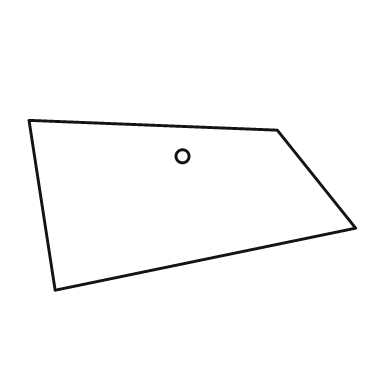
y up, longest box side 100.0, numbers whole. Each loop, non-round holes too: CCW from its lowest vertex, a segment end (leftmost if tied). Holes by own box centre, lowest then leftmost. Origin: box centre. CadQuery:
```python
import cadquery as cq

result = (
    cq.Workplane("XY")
    .moveTo(-42.0, -26.0)
    .lineTo(50.0, -7.0)
    .lineTo(26.0, 23.0)
    .lineTo(-50.0, 26.0)
    .close()
    .moveTo(-3.0, 15.0)
    .circle(2.0)
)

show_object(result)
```